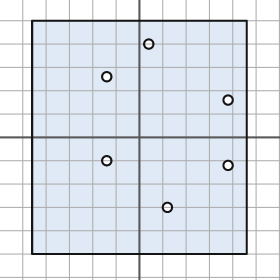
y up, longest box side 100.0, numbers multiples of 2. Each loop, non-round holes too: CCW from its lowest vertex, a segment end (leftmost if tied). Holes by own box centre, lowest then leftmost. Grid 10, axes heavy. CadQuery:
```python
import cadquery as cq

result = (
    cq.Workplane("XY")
    .moveTo(-46.0, -50.0)
    .lineTo(46.0, -50.0)
    .lineTo(46.0, 50.0)
    .lineTo(-46.0, 50.0)
    .close()
    .moveTo(12.0, -30.0)
    .circle(2.0)
    .moveTo(38.0, -12.0)
    .circle(2.0)
    .moveTo(-14.0, -10.0)
    .circle(2.0)
    .moveTo(38.0, 16.0)
    .circle(2.0)
    .moveTo(-14.0, 26.0)
    .circle(2.0)
    .moveTo(4.0, 40.0)
    .circle(2.0)
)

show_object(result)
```